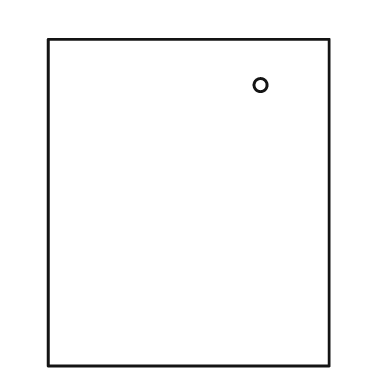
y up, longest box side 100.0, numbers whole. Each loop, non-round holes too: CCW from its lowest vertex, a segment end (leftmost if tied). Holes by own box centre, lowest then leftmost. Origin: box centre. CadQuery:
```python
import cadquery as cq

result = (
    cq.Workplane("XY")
    .moveTo(-43.0, -50.0)
    .lineTo(43.0, -50.0)
    .lineTo(43.0, 50.0)
    .lineTo(-43.0, 50.0)
    .close()
    .moveTo(22.0, 36.0)
    .circle(2.0)
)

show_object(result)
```